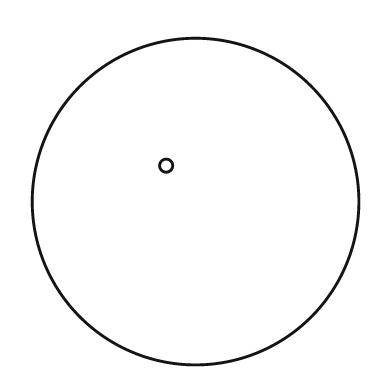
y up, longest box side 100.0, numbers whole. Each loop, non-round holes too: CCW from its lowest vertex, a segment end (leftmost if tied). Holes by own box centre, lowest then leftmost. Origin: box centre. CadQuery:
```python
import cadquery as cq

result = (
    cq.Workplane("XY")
    .moveTo(0.0, 0.0)
    .circle(50.0)
    .moveTo(-9.0, 11.0)
    .circle(2.0)
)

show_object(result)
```